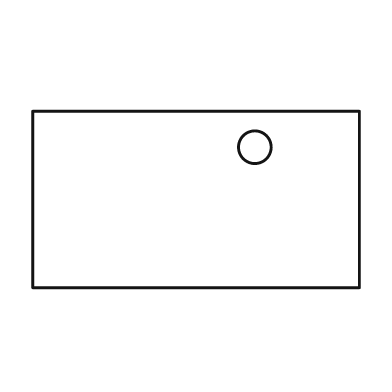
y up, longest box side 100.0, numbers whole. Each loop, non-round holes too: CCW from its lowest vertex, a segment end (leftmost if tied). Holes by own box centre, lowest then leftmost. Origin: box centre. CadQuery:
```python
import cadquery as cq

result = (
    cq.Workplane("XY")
    .moveTo(-50.0, -27.0)
    .lineTo(50.0, -27.0)
    .lineTo(50.0, 27.0)
    .lineTo(-50.0, 27.0)
    .close()
    .moveTo(18.0, 16.0)
    .circle(5.0)
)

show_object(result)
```